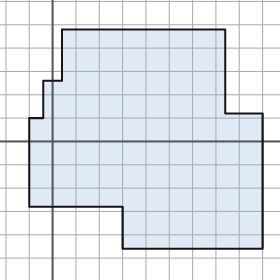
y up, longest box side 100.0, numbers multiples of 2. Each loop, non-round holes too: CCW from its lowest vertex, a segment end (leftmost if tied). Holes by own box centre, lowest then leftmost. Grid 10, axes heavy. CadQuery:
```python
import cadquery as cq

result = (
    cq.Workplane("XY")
    .moveTo(30.0, -46.0)
    .lineTo(90.0, -46.0)
    .lineTo(90.0, 12.0)
    .lineTo(74.0, 12.0)
    .lineTo(74.0, 48.0)
    .lineTo(4.0, 48.0)
    .lineTo(4.0, 26.0)
    .lineTo(-4.0, 26.0)
    .lineTo(-4.0, 10.0)
    .lineTo(-10.0, 10.0)
    .lineTo(-10.0, -28.0)
    .lineTo(30.0, -28.0)
    .close()
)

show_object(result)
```